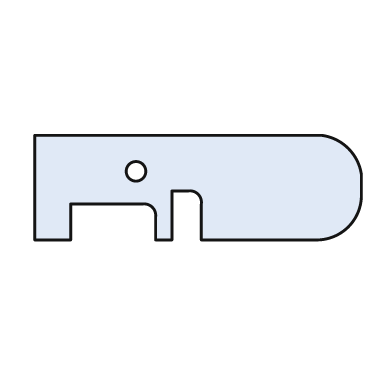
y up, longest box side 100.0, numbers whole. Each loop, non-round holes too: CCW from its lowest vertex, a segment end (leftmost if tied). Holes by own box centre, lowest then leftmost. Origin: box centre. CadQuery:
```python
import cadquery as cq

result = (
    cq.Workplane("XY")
    .moveTo(-50.0, -16.0)
    .lineTo(-39.0, -16.0)
    .lineTo(-39.0, -5.0)
    .lineTo(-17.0, -5.0)
    .threePointArc((-14.0, -6.0), (-13.0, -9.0))
    .lineTo(-13.0, -16.0)
    .lineTo(-8.0, -16.0)
    .lineTo(-8.0, -1.0)
    .lineTo(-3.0, -1.0)
    .threePointArc((0.0, -2.0), (1.0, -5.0))
    .lineTo(1.0, -16.0)
    .lineTo(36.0, -16.0)
    .threePointArc((46.0, -12.0), (50.0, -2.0))
    .lineTo(50.0, 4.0)
    .threePointArc((46.0, 12.0), (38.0, 16.0))
    .lineTo(-50.0, 16.0)
    .close()
    .moveTo(-19.0, 5.0)
    .circle(3.0)
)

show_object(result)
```